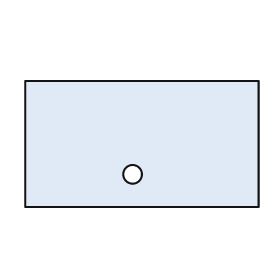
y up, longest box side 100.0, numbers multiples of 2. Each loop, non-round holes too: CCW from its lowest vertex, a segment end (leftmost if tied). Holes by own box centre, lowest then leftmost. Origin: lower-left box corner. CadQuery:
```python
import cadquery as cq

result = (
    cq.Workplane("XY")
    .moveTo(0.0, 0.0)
    .lineTo(100.0, 0.0)
    .lineTo(100.0, 54.0)
    .lineTo(0.0, 54.0)
    .close()
    .moveTo(46.0, 14.0)
    .circle(4.0)
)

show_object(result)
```